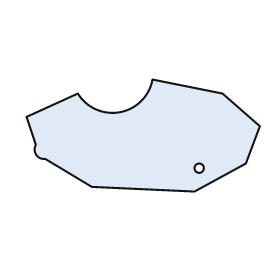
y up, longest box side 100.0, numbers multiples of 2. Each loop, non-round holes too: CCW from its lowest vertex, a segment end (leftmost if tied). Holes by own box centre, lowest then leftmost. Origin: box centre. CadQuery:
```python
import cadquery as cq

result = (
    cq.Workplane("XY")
    .moveTo(22.0, -24.0)
    .lineTo(44.0, -12.0)
    .lineTo(50.0, 4.0)
    .lineTo(34.0, 18.0)
    .lineTo(4.0, 24.0)
    .threePointArc((-10.0, 10.0), (-28.0, 18.0))
    .lineTo(-50.0, 8.0)
    .lineTo(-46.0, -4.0)
    .threePointArc((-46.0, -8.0), (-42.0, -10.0))
    .lineTo(-22.0, -22.0)
    .close()
    .moveTo(24.0, -14.0)
    .circle(2.0)
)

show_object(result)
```